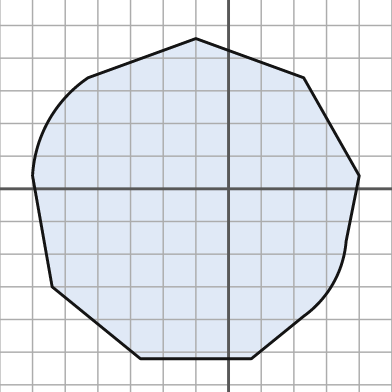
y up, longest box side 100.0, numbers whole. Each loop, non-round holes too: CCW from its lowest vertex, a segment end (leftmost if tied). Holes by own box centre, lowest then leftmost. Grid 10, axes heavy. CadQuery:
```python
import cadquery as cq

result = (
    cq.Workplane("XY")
    .moveTo(-27.0, -52.0)
    .lineTo(7.0, -52.0)
    .lineTo(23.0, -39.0)
    .threePointArc((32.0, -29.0), (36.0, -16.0))
    .lineTo(40.0, 4.0)
    .lineTo(23.0, 34.0)
    .lineTo(-10.0, 46.0)
    .lineTo(-43.0, 34.0)
    .threePointArc((-55.0, 21.0), (-60.0, 4.0))
    .lineTo(-54.0, -30.0)
    .close()
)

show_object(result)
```